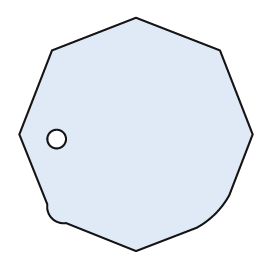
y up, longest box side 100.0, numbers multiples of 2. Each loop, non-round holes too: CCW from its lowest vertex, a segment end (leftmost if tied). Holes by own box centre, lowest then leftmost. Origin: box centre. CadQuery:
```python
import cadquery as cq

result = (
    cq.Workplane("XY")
    .moveTo(0.0, -50.0)
    .lineTo(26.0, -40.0)
    .threePointArc((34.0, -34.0), (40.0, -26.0))
    .lineTo(50.0, 0.0)
    .lineTo(36.0, 36.0)
    .lineTo(0.0, 50.0)
    .lineTo(-36.0, 36.0)
    .lineTo(-50.0, 0.0)
    .lineTo(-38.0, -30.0)
    .threePointArc((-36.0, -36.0), (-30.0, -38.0))
    .close()
    .moveTo(-34.0, -2.0)
    .circle(4.0)
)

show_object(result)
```